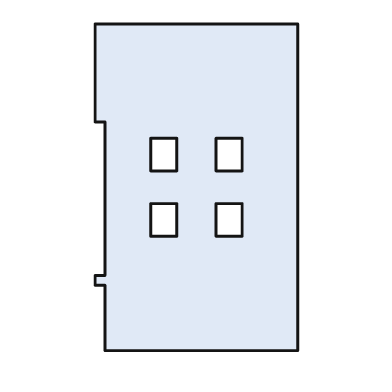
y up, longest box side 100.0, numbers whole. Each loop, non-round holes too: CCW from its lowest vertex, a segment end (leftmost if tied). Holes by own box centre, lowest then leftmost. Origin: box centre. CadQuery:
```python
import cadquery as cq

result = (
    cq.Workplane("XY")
    .moveTo(-28.0, -50.0)
    .lineTo(31.0, -50.0)
    .lineTo(31.0, 50.0)
    .lineTo(-31.0, 50.0)
    .lineTo(-31.0, 20.0)
    .lineTo(-28.0, 20.0)
    .lineTo(-28.0, -27.0)
    .lineTo(-31.0, -27.0)
    .lineTo(-31.0, -30.0)
    .lineTo(-28.0, -30.0)
    .close()
    .moveTo(-14.0, -15.0)
    .lineTo(-6.0, -15.0)
    .lineTo(-6.0, -5.0)
    .lineTo(-14.0, -5.0)
    .close()
    .moveTo(6.0, -15.0)
    .lineTo(14.0, -15.0)
    .lineTo(14.0, -5.0)
    .lineTo(6.0, -5.0)
    .close()
    .moveTo(-14.0, 5.0)
    .lineTo(-6.0, 5.0)
    .lineTo(-6.0, 15.0)
    .lineTo(-14.0, 15.0)
    .close()
    .moveTo(6.0, 5.0)
    .lineTo(14.0, 5.0)
    .lineTo(14.0, 15.0)
    .lineTo(6.0, 15.0)
    .close()
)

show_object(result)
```